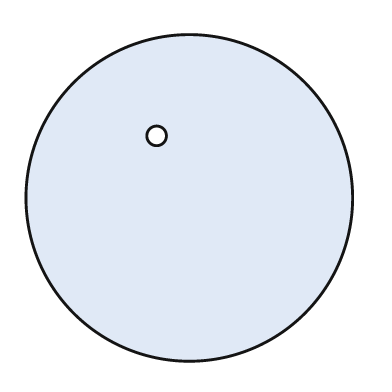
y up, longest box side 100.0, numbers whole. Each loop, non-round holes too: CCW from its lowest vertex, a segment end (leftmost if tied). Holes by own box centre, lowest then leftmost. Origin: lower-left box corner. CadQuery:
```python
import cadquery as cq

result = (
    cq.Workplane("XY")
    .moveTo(50.0, 50.0)
    .circle(50.0)
    .moveTo(40.0, 69.0)
    .circle(3.0)
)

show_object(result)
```